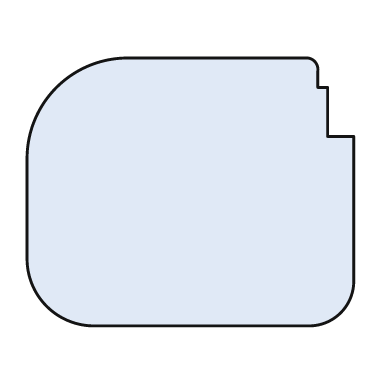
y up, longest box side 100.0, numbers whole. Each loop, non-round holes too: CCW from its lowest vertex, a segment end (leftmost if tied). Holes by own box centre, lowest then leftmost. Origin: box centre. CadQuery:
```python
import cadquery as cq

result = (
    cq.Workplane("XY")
    .moveTo(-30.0, -41.0)
    .lineTo(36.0, -41.0)
    .threePointArc((46.0, -37.0), (50.0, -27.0))
    .lineTo(50.0, 17.0)
    .lineTo(42.0, 17.0)
    .lineTo(42.0, 32.0)
    .lineTo(39.0, 32.0)
    .lineTo(39.0, 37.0)
    .threePointArc((38.0, 40.0), (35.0, 41.0))
    .lineTo(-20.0, 41.0)
    .threePointArc((-41.0, 32.0), (-50.0, 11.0))
    .lineTo(-50.0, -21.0)
    .threePointArc((-44.0, -35.0), (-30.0, -41.0))
    .close()
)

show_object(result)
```